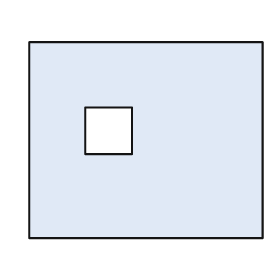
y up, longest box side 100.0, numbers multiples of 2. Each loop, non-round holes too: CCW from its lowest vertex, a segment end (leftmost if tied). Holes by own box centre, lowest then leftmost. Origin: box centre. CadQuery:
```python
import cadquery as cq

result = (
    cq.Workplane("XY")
    .moveTo(-50.0, -42.0)
    .lineTo(50.0, -42.0)
    .lineTo(50.0, 42.0)
    .lineTo(-50.0, 42.0)
    .close()
    .moveTo(-26.0, -6.0)
    .lineTo(-6.0, -6.0)
    .lineTo(-6.0, 14.0)
    .lineTo(-26.0, 14.0)
    .close()
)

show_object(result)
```